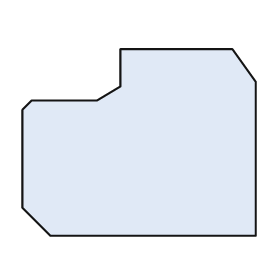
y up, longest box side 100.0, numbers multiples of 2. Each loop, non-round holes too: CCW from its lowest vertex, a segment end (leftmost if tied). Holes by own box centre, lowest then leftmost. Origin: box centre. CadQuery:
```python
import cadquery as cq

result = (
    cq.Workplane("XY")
    .moveTo(-38.0, -40.0)
    .lineTo(50.0, -40.0)
    .lineTo(50.0, 26.0)
    .lineTo(40.0, 40.0)
    .lineTo(-8.0, 40.0)
    .lineTo(-8.0, 24.0)
    .lineTo(-18.0, 18.0)
    .lineTo(-46.0, 18.0)
    .lineTo(-50.0, 14.0)
    .lineTo(-50.0, -28.0)
    .close()
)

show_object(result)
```